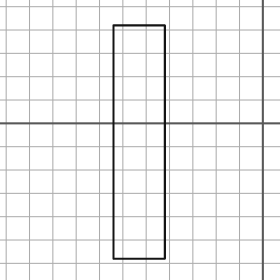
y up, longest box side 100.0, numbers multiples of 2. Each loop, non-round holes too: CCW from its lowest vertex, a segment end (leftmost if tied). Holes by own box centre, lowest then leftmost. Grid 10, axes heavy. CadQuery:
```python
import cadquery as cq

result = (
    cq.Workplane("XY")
    .moveTo(-64.0, -58.0)
    .lineTo(-42.0, -58.0)
    .lineTo(-42.0, 42.0)
    .lineTo(-64.0, 42.0)
    .close()
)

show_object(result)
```